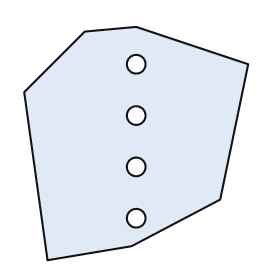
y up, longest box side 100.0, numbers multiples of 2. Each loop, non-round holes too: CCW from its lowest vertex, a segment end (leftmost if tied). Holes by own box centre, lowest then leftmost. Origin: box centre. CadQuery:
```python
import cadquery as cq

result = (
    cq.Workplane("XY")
    .moveTo(-38.0, -50.0)
    .lineTo(-2.0, -44.0)
    .lineTo(36.0, -24.0)
    .lineTo(48.0, 34.0)
    .lineTo(0.0, 50.0)
    .lineTo(-22.0, 48.0)
    .lineTo(-48.0, 22.0)
    .close()
    .moveTo(0.0, -32.0)
    .circle(4.0)
    .moveTo(0.0, -10.0)
    .circle(4.0)
    .moveTo(0.0, 12.0)
    .circle(4.0)
    .moveTo(0.0, 34.0)
    .circle(4.0)
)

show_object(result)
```